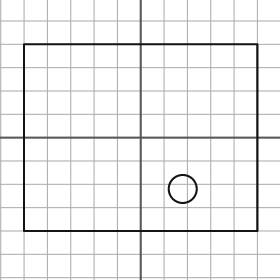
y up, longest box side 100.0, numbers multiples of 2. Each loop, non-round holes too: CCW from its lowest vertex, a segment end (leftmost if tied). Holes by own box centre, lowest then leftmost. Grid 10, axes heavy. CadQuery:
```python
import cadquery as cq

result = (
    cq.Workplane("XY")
    .moveTo(-50.0, -40.0)
    .lineTo(50.0, -40.0)
    .lineTo(50.0, 40.0)
    .lineTo(-50.0, 40.0)
    .close()
    .moveTo(18.0, -22.0)
    .circle(6.0)
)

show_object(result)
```